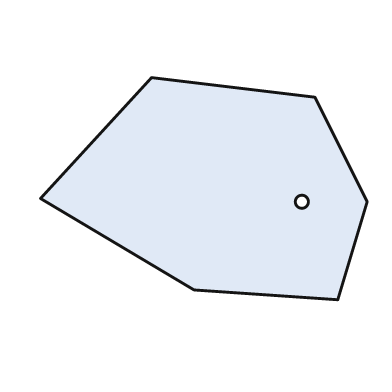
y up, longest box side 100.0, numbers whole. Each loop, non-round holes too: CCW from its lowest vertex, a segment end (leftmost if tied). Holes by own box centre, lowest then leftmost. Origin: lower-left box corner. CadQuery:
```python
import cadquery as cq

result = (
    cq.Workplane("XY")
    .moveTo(91.0, 0.0)
    .lineTo(100.0, 30.0)
    .lineTo(84.0, 62.0)
    .lineTo(34.0, 68.0)
    .lineTo(0.0, 31.0)
    .lineTo(47.0, 3.0)
    .close()
    .moveTo(80.0, 30.0)
    .circle(2.0)
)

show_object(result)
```